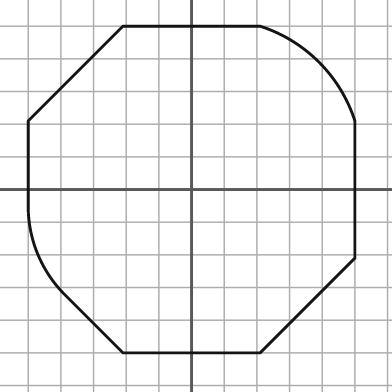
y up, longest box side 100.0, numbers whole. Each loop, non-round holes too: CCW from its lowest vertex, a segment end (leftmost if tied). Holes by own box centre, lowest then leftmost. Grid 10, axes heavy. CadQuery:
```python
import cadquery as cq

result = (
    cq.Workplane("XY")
    .moveTo(-21.0, -50.0)
    .lineTo(21.0, -50.0)
    .lineTo(50.0, -21.0)
    .lineTo(50.0, 21.0)
    .threePointArc((39.0, 39.0), (21.0, 50.0))
    .lineTo(-21.0, 50.0)
    .lineTo(-50.0, 21.0)
    .lineTo(-50.0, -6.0)
    .threePointArc((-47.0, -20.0), (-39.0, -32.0))
    .close()
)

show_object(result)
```